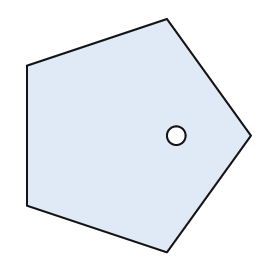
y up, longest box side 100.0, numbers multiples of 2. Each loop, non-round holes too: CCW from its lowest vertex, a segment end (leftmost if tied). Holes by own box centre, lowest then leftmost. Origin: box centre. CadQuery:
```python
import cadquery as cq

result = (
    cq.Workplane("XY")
    .moveTo(12.0, -50.0)
    .lineTo(48.0, 0.0)
    .lineTo(12.0, 50.0)
    .lineTo(-48.0, 30.0)
    .lineTo(-48.0, -30.0)
    .close()
    .moveTo(16.0, 0.0)
    .circle(4.0)
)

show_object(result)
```